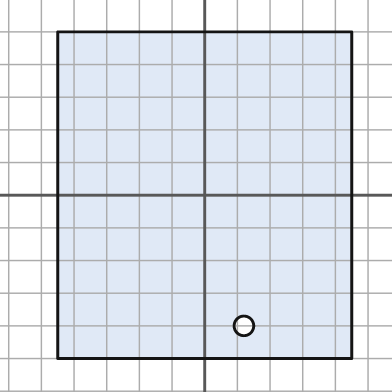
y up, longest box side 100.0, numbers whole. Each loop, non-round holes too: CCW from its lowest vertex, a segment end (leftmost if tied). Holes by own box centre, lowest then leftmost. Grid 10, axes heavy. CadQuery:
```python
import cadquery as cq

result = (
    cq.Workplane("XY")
    .moveTo(-45.0, -50.0)
    .lineTo(45.0, -50.0)
    .lineTo(45.0, 50.0)
    .lineTo(-45.0, 50.0)
    .close()
    .moveTo(12.0, -40.0)
    .circle(3.0)
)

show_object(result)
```